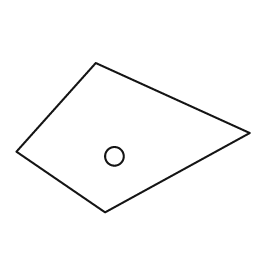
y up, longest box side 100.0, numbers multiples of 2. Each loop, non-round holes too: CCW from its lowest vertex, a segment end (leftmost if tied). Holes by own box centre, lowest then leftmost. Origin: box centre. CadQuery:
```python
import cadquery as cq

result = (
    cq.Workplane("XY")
    .moveTo(-12.0, -32.0)
    .lineTo(50.0, 2.0)
    .lineTo(-16.0, 32.0)
    .lineTo(-50.0, -6.0)
    .close()
    .moveTo(-8.0, -8.0)
    .circle(4.0)
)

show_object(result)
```